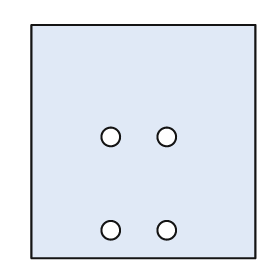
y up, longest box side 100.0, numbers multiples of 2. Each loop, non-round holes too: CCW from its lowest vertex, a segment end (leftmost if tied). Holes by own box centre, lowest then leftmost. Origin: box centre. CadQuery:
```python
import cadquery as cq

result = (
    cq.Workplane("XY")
    .moveTo(-48.0, -50.0)
    .lineTo(48.0, -50.0)
    .lineTo(48.0, 50.0)
    .lineTo(-48.0, 50.0)
    .close()
    .moveTo(-14.0, -38.0)
    .circle(4.0)
    .moveTo(10.0, -38.0)
    .circle(4.0)
    .moveTo(-14.0, 2.0)
    .circle(4.0)
    .moveTo(10.0, 2.0)
    .circle(4.0)
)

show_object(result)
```